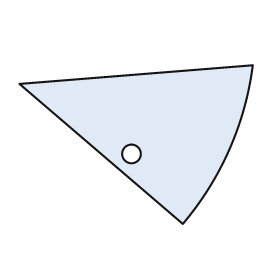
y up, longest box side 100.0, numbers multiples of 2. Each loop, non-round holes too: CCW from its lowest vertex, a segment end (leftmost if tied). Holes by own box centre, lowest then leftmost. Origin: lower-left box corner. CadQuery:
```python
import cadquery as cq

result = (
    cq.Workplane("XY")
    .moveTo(70.0, 0.0)
    .threePointArc((90.0, 32.0), (100.0, 68.0))
    .lineTo(0.0, 60.0)
    .close()
    .moveTo(48.0, 30.0)
    .circle(4.0)
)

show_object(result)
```